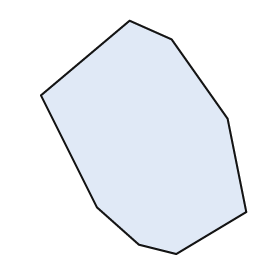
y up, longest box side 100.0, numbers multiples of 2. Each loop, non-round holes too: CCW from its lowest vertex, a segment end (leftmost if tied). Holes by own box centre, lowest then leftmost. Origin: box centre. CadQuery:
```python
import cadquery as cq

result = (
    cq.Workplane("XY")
    .moveTo(14.0, -50.0)
    .lineTo(44.0, -32.0)
    .lineTo(36.0, 8.0)
    .lineTo(12.0, 42.0)
    .lineTo(-6.0, 50.0)
    .lineTo(-44.0, 18.0)
    .lineTo(-20.0, -30.0)
    .lineTo(-2.0, -46.0)
    .close()
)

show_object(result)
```